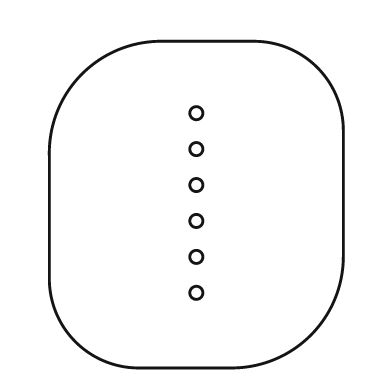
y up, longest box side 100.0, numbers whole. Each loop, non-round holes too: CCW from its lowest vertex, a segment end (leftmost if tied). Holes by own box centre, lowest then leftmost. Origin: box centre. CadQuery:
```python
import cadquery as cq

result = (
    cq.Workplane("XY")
    .moveTo(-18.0, -50.0)
    .lineTo(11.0, -50.0)
    .threePointArc((35.0, -40.0), (45.0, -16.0))
    .lineTo(45.0, 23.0)
    .threePointArc((37.0, 42.0), (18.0, 50.0))
    .lineTo(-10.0, 50.0)
    .threePointArc((-35.0, 40.0), (-45.0, 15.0))
    .lineTo(-45.0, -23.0)
    .threePointArc((-37.0, -42.0), (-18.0, -50.0))
    .close()
    .moveTo(0.0, -27.0)
    .circle(2.0)
    .moveTo(0.0, -16.0)
    .circle(2.0)
    .moveTo(0.0, -5.0)
    .circle(2.0)
    .moveTo(0.0, 6.0)
    .circle(2.0)
    .moveTo(0.0, 17.0)
    .circle(2.0)
    .moveTo(0.0, 28.0)
    .circle(2.0)
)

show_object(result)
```